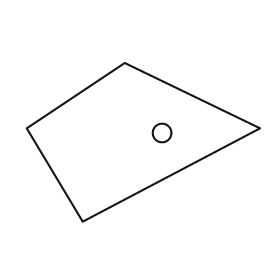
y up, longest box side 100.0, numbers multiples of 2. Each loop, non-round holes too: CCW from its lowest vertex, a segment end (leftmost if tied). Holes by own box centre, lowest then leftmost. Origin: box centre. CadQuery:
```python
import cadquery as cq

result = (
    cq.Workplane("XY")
    .moveTo(-26.0, -34.0)
    .lineTo(50.0, 6.0)
    .lineTo(-8.0, 34.0)
    .lineTo(-50.0, 6.0)
    .close()
    .moveTo(8.0, 4.0)
    .circle(4.0)
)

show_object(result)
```